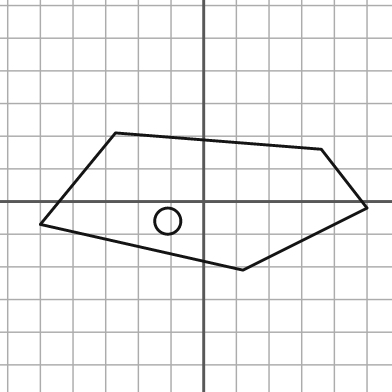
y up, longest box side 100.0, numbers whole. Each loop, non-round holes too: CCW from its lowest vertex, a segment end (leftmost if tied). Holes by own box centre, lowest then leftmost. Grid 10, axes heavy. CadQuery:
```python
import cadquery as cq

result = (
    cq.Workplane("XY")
    .moveTo(12.0, -21.0)
    .lineTo(50.0, -2.0)
    .lineTo(36.0, 16.0)
    .lineTo(-27.0, 21.0)
    .lineTo(-50.0, -7.0)
    .close()
    .moveTo(-11.0, -6.0)
    .circle(4.0)
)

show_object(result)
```